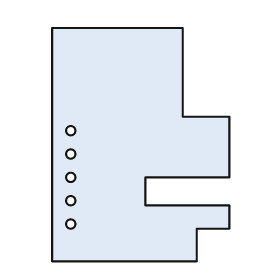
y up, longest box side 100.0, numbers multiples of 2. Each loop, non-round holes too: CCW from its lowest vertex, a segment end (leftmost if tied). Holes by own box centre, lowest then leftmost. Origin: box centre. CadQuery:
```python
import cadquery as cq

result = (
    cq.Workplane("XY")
    .moveTo(-38.0, -50.0)
    .lineTo(24.0, -50.0)
    .lineTo(24.0, -36.0)
    .lineTo(38.0, -36.0)
    .lineTo(38.0, -26.0)
    .lineTo(2.0, -26.0)
    .lineTo(2.0, -14.0)
    .lineTo(38.0, -14.0)
    .lineTo(38.0, 12.0)
    .lineTo(18.0, 12.0)
    .lineTo(18.0, 50.0)
    .lineTo(-38.0, 50.0)
    .close()
    .moveTo(-30.0, -34.0)
    .circle(2.0)
    .moveTo(-30.0, -24.0)
    .circle(2.0)
    .moveTo(-30.0, -14.0)
    .circle(2.0)
    .moveTo(-30.0, -4.0)
    .circle(2.0)
    .moveTo(-30.0, 6.0)
    .circle(2.0)
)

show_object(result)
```